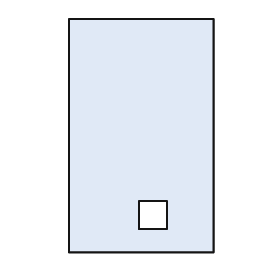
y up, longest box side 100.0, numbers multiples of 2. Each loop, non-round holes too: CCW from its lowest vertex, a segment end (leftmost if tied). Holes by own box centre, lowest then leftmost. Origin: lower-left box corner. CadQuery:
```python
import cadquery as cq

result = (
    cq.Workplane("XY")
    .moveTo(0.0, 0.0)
    .lineTo(62.0, 0.0)
    .lineTo(62.0, 100.0)
    .lineTo(0.0, 100.0)
    .close()
    .moveTo(30.0, 10.0)
    .lineTo(42.0, 10.0)
    .lineTo(42.0, 22.0)
    .lineTo(30.0, 22.0)
    .close()
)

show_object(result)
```